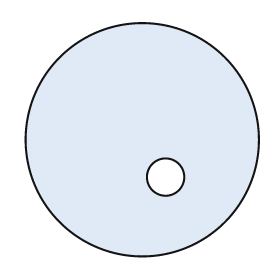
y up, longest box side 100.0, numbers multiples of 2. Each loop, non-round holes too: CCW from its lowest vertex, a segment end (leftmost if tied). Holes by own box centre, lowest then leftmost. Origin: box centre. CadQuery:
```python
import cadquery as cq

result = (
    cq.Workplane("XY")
    .moveTo(0.0, 0.0)
    .circle(50.0)
    .moveTo(10.0, -16.0)
    .circle(8.0)
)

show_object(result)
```